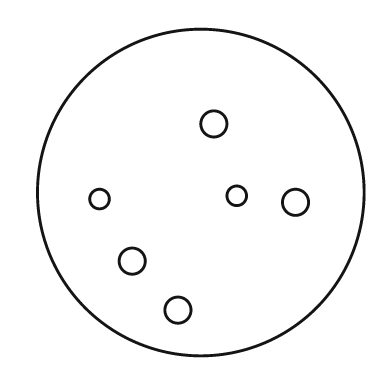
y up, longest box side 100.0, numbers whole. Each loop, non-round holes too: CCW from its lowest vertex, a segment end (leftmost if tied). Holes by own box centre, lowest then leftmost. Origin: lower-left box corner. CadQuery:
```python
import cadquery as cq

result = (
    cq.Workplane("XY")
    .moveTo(50.0, 50.0)
    .circle(50.0)
    .moveTo(43.0, 14.0)
    .circle(4.0)
    .moveTo(29.0, 29.0)
    .circle(4.0)
    .moveTo(79.0, 47.0)
    .circle(4.0)
    .moveTo(19.0, 48.0)
    .circle(3.0)
    .moveTo(61.0, 49.0)
    .circle(3.0)
    .moveTo(54.0, 71.0)
    .circle(4.0)
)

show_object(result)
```